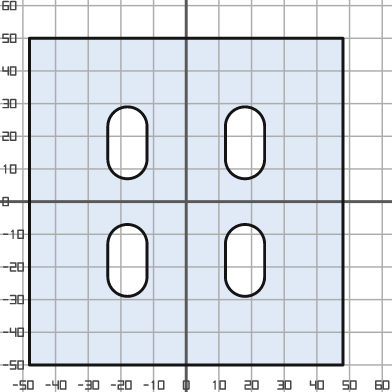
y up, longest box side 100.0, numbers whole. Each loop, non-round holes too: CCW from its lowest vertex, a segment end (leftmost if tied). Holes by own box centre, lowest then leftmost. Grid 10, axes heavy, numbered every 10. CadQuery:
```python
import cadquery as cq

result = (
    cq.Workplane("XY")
    .moveTo(-48.0, -50.0)
    .lineTo(48.0, -50.0)
    .lineTo(48.0, 50.0)
    .lineTo(-48.0, 50.0)
    .close()
    .moveTo(-24.0, -23.0)
    .threePointArc((-18.0, -29.0), (-12.0, -23.0))
    .lineTo(-12.0, -13.0)
    .threePointArc((-18.0, -7.0), (-24.0, -13.0))
    .close()
    .moveTo(12.0, -23.0)
    .threePointArc((18.0, -29.0), (24.0, -23.0))
    .lineTo(24.0, -13.0)
    .threePointArc((18.0, -7.0), (12.0, -13.0))
    .close()
    .moveTo(-24.0, 13.0)
    .threePointArc((-18.0, 7.0), (-12.0, 13.0))
    .lineTo(-12.0, 23.0)
    .threePointArc((-18.0, 29.0), (-24.0, 23.0))
    .close()
    .moveTo(12.0, 13.0)
    .threePointArc((18.0, 7.0), (24.0, 13.0))
    .lineTo(24.0, 23.0)
    .threePointArc((18.0, 29.0), (12.0, 23.0))
    .close()
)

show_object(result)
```